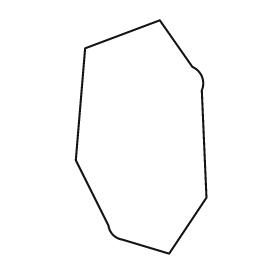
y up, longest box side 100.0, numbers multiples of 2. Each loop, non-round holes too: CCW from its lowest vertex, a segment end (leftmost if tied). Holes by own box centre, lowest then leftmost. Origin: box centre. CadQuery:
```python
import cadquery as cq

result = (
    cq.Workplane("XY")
    .moveTo(12.0, -50.0)
    .lineTo(28.0, -26.0)
    .lineTo(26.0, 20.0)
    .threePointArc((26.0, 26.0), (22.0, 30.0))
    .lineTo(8.0, 50.0)
    .lineTo(-24.0, 38.0)
    .lineTo(-28.0, -10.0)
    .lineTo(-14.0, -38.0)
    .threePointArc((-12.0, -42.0), (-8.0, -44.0))
    .close()
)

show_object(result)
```